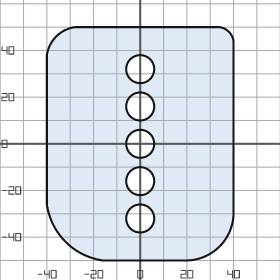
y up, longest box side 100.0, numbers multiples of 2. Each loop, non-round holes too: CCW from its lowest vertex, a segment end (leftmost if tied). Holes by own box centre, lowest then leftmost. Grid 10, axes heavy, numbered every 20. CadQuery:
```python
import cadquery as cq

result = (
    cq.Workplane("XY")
    .moveTo(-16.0, -50.0)
    .lineTo(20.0, -50.0)
    .threePointArc((34.0, -44.0), (40.0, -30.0))
    .lineTo(40.0, 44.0)
    .threePointArc((38.0, 48.0), (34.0, 50.0))
    .lineTo(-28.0, 50.0)
    .threePointArc((-36.0, 46.0), (-40.0, 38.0))
    .lineTo(-40.0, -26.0)
    .threePointArc((-32.0, -42.0), (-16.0, -50.0))
    .close()
    .moveTo(0.0, -32.0)
    .circle(6.0)
    .moveTo(0.0, -16.0)
    .circle(6.0)
    .moveTo(0.0, 0.0)
    .circle(6.0)
    .moveTo(0.0, 16.0)
    .circle(6.0)
    .moveTo(0.0, 32.0)
    .circle(6.0)
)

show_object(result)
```